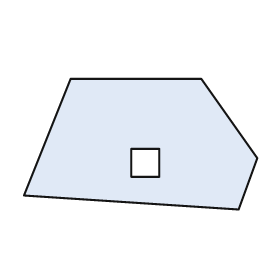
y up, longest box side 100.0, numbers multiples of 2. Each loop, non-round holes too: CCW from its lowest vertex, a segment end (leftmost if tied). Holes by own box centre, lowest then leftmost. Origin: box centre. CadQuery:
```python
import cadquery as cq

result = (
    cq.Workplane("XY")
    .moveTo(42.0, -28.0)
    .lineTo(50.0, -6.0)
    .lineTo(26.0, 28.0)
    .lineTo(-30.0, 28.0)
    .lineTo(-50.0, -22.0)
    .close()
    .moveTo(-4.0, -14.0)
    .lineTo(8.0, -14.0)
    .lineTo(8.0, -2.0)
    .lineTo(-4.0, -2.0)
    .close()
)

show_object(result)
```